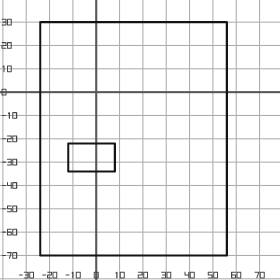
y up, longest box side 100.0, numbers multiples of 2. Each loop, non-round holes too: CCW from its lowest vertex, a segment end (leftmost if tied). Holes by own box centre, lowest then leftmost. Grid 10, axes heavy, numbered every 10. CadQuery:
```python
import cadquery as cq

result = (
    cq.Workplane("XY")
    .moveTo(-24.0, -70.0)
    .lineTo(56.0, -70.0)
    .lineTo(56.0, 30.0)
    .lineTo(-24.0, 30.0)
    .close()
    .moveTo(-12.0, -34.0)
    .lineTo(8.0, -34.0)
    .lineTo(8.0, -22.0)
    .lineTo(-12.0, -22.0)
    .close()
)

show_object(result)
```